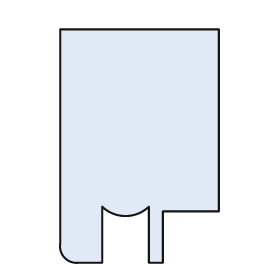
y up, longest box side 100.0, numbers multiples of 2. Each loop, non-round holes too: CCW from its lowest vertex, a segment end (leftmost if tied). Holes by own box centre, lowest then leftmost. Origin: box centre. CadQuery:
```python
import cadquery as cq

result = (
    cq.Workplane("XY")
    .moveTo(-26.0, -50.0)
    .lineTo(-16.0, -50.0)
    .lineTo(-16.0, -26.0)
    .threePointArc((-6.0, -30.0), (4.0, -26.0))
    .lineTo(4.0, -50.0)
    .lineTo(10.0, -50.0)
    .lineTo(10.0, -28.0)
    .lineTo(34.0, -28.0)
    .lineTo(34.0, 50.0)
    .lineTo(-34.0, 50.0)
    .lineTo(-34.0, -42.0)
    .threePointArc((-32.0, -48.0), (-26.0, -50.0))
    .close()
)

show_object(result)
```